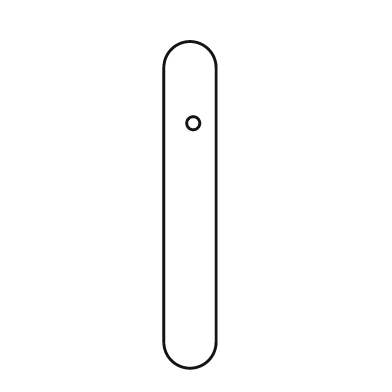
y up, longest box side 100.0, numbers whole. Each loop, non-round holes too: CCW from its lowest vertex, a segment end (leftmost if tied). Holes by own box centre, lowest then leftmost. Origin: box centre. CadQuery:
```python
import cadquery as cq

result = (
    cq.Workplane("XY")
    .moveTo(-8.0, -42.0)
    .threePointArc((0.0, -50.0), (8.0, -42.0))
    .lineTo(8.0, 42.0)
    .threePointArc((0.0, 50.0), (-8.0, 42.0))
    .close()
    .moveTo(1.0, 25.0)
    .circle(2.0)
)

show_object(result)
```